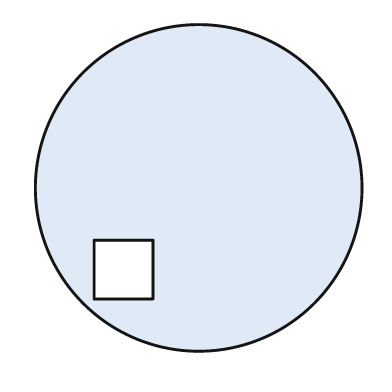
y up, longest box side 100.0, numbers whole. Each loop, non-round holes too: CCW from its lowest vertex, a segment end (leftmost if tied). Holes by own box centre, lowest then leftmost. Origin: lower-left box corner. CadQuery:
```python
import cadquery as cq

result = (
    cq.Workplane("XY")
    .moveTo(50.0, 50.0)
    .circle(50.0)
    .moveTo(18.0, 16.0)
    .lineTo(36.0, 16.0)
    .lineTo(36.0, 34.0)
    .lineTo(18.0, 34.0)
    .close()
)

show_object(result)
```